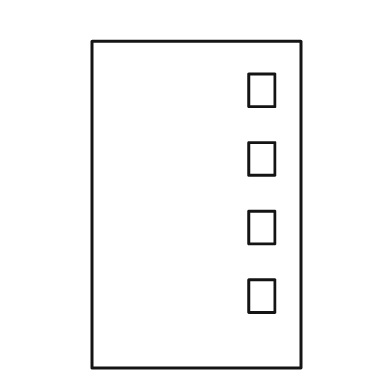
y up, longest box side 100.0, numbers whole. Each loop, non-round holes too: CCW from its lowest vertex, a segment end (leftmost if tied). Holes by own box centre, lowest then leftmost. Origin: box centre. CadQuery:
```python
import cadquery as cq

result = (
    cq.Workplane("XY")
    .moveTo(-32.0, -50.0)
    .lineTo(32.0, -50.0)
    .lineTo(32.0, 50.0)
    .lineTo(-32.0, 50.0)
    .close()
    .moveTo(16.0, -33.0)
    .lineTo(24.0, -33.0)
    .lineTo(24.0, -23.0)
    .lineTo(16.0, -23.0)
    .close()
    .moveTo(16.0, -12.0)
    .lineTo(24.0, -12.0)
    .lineTo(24.0, -2.0)
    .lineTo(16.0, -2.0)
    .close()
    .moveTo(16.0, 9.0)
    .lineTo(24.0, 9.0)
    .lineTo(24.0, 19.0)
    .lineTo(16.0, 19.0)
    .close()
    .moveTo(16.0, 30.0)
    .lineTo(24.0, 30.0)
    .lineTo(24.0, 40.0)
    .lineTo(16.0, 40.0)
    .close()
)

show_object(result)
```